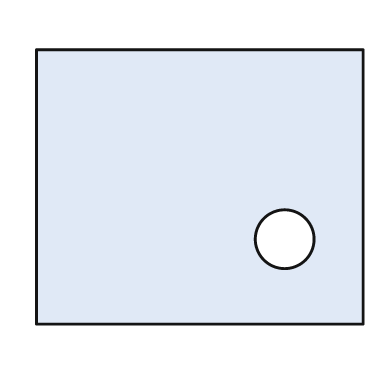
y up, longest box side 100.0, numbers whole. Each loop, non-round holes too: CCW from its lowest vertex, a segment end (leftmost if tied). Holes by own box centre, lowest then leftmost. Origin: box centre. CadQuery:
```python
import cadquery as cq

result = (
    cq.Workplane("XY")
    .moveTo(-50.0, -42.0)
    .lineTo(50.0, -42.0)
    .lineTo(50.0, 42.0)
    .lineTo(-50.0, 42.0)
    .close()
    .moveTo(26.0, -16.0)
    .circle(9.0)
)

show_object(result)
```